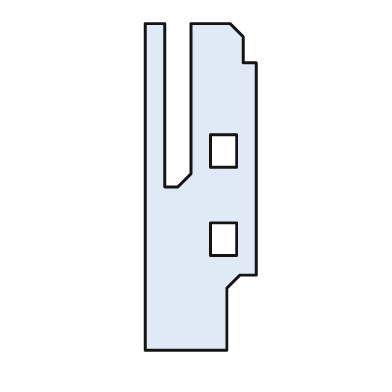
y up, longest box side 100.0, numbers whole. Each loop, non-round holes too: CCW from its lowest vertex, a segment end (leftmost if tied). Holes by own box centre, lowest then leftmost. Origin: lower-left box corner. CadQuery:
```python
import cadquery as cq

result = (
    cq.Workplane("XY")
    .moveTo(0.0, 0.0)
    .lineTo(25.0, 0.0)
    .lineTo(25.0, 19.0)
    .lineTo(29.0, 23.0)
    .lineTo(34.0, 23.0)
    .lineTo(34.0, 88.0)
    .lineTo(30.0, 88.0)
    .lineTo(30.0, 96.0)
    .lineTo(26.0, 100.0)
    .lineTo(14.0, 100.0)
    .lineTo(14.0, 54.0)
    .lineTo(10.0, 50.0)
    .lineTo(6.0, 50.0)
    .lineTo(6.0, 100.0)
    .lineTo(0.0, 100.0)
    .close()
    .moveTo(20.0, 29.0)
    .lineTo(28.0, 29.0)
    .lineTo(28.0, 39.0)
    .lineTo(20.0, 39.0)
    .close()
    .moveTo(20.0, 56.0)
    .lineTo(28.0, 56.0)
    .lineTo(28.0, 66.0)
    .lineTo(20.0, 66.0)
    .close()
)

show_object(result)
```